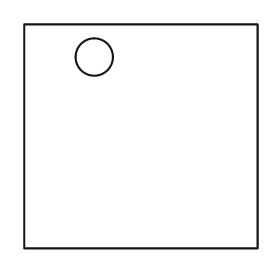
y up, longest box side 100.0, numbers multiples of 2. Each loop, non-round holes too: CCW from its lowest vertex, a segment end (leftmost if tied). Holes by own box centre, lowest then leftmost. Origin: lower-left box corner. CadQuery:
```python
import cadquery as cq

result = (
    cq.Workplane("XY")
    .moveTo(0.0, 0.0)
    .lineTo(100.0, 0.0)
    .lineTo(100.0, 96.0)
    .lineTo(0.0, 96.0)
    .close()
    .moveTo(30.0, 82.0)
    .circle(8.0)
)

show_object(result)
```